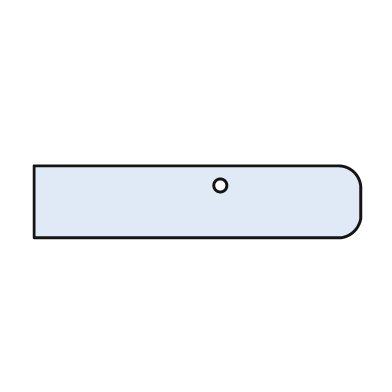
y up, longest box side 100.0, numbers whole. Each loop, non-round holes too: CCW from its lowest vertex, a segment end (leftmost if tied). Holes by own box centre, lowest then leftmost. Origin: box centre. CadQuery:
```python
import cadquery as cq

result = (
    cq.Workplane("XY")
    .moveTo(-50.0, -11.0)
    .lineTo(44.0, -11.0)
    .threePointArc((48.0, -9.0), (50.0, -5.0))
    .lineTo(50.0, 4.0)
    .threePointArc((48.0, 9.0), (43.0, 11.0))
    .lineTo(-50.0, 11.0)
    .close()
    .moveTo(7.0, 5.0)
    .circle(2.0)
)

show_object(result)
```